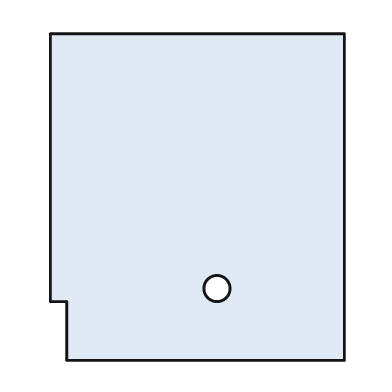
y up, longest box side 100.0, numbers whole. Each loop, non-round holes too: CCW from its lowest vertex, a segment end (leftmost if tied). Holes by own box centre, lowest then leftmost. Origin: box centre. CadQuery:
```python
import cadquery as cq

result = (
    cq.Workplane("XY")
    .moveTo(-40.0, -50.0)
    .lineTo(45.0, -50.0)
    .lineTo(45.0, 50.0)
    .lineTo(-45.0, 50.0)
    .lineTo(-45.0, -32.0)
    .lineTo(-40.0, -32.0)
    .close()
    .moveTo(6.0, -28.0)
    .circle(4.0)
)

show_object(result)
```